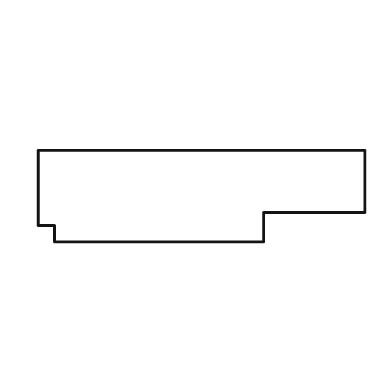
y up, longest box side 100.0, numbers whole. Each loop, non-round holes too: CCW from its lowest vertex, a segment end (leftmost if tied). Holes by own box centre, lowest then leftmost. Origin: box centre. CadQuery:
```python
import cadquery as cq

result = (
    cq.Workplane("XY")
    .moveTo(-45.0, -14.0)
    .lineTo(19.0, -14.0)
    .lineTo(19.0, -5.0)
    .lineTo(50.0, -5.0)
    .lineTo(50.0, 14.0)
    .lineTo(-50.0, 14.0)
    .lineTo(-50.0, -9.0)
    .lineTo(-45.0, -9.0)
    .close()
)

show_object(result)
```